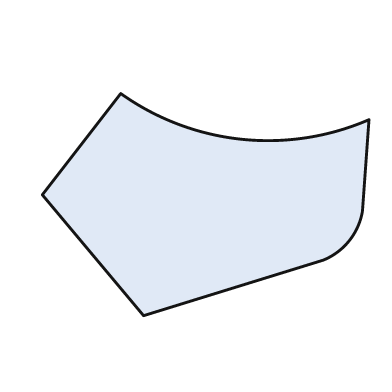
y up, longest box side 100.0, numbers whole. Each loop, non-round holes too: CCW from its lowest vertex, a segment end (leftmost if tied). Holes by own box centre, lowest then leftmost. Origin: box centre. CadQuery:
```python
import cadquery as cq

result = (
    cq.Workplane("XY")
    .moveTo(-19.0, -34.0)
    .lineTo(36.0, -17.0)
    .threePointArc((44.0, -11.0), (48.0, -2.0))
    .lineTo(50.0, 26.0)
    .threePointArc((11.0, 20.0), (-26.0, 34.0))
    .lineTo(-50.0, 3.0)
    .close()
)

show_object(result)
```